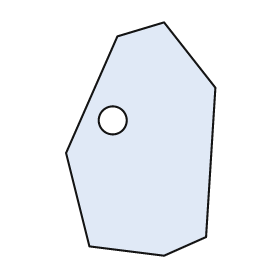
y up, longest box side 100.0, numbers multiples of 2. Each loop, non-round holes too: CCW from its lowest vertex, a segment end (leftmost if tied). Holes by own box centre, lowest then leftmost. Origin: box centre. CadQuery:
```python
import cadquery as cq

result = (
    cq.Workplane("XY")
    .moveTo(10.0, -50.0)
    .lineTo(28.0, -42.0)
    .lineTo(32.0, 22.0)
    .lineTo(10.0, 50.0)
    .lineTo(-10.0, 44.0)
    .lineTo(-32.0, -6.0)
    .lineTo(-22.0, -46.0)
    .close()
    .moveTo(-12.0, 8.0)
    .circle(6.0)
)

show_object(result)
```